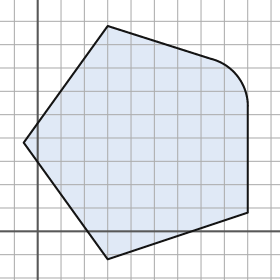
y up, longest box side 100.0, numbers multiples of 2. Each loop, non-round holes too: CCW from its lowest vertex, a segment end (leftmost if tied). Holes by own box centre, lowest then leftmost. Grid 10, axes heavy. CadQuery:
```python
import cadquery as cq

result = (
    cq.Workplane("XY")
    .moveTo(30.0, -12.0)
    .lineTo(90.0, 8.0)
    .lineTo(90.0, 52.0)
    .threePointArc((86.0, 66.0), (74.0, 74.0))
    .lineTo(30.0, 88.0)
    .lineTo(-6.0, 38.0)
    .close()
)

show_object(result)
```